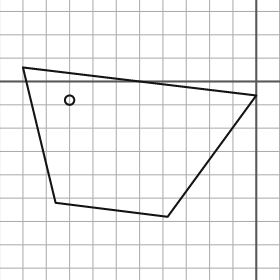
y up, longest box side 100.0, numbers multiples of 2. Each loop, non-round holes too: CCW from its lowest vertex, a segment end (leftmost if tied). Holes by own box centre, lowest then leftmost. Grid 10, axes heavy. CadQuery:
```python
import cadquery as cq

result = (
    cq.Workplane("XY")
    .moveTo(-38.0, -58.0)
    .lineTo(0.0, -6.0)
    .lineTo(-100.0, 6.0)
    .lineTo(-86.0, -52.0)
    .close()
    .moveTo(-80.0, -8.0)
    .circle(2.0)
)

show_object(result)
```